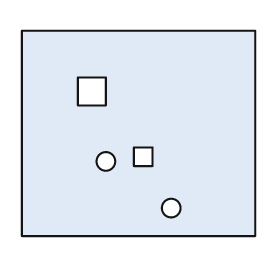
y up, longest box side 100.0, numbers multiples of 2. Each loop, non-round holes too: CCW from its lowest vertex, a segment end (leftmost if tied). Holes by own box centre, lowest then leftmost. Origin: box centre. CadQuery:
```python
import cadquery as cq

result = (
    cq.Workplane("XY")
    .moveTo(-50.0, -44.0)
    .lineTo(50.0, -44.0)
    .lineTo(50.0, 44.0)
    .lineTo(-50.0, 44.0)
    .close()
    .moveTo(14.0, -32.0)
    .circle(4.0)
    .moveTo(-14.0, -12.0)
    .circle(4.0)
    .moveTo(-2.0, -14.0)
    .lineTo(6.0, -14.0)
    .lineTo(6.0, -6.0)
    .lineTo(-2.0, -6.0)
    .close()
    .moveTo(-26.0, 12.0)
    .lineTo(-14.0, 12.0)
    .lineTo(-14.0, 24.0)
    .lineTo(-26.0, 24.0)
    .close()
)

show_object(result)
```